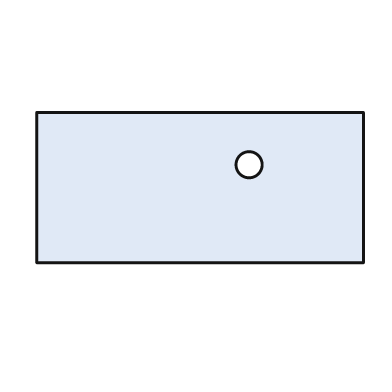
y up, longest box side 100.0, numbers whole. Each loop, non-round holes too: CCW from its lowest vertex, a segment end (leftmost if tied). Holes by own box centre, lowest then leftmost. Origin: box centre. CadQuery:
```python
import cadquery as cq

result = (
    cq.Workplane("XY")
    .moveTo(-50.0, -23.0)
    .lineTo(50.0, -23.0)
    .lineTo(50.0, 23.0)
    .lineTo(-50.0, 23.0)
    .close()
    .moveTo(15.0, 7.0)
    .circle(4.0)
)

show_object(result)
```